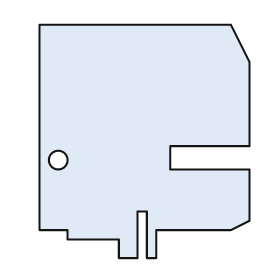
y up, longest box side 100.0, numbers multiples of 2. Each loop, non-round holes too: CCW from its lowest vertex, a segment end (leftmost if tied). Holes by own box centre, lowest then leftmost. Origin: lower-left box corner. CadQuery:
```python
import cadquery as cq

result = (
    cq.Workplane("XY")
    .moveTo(34.0, 0.0)
    .lineTo(42.0, 0.0)
    .lineTo(42.0, 20.0)
    .lineTo(46.0, 20.0)
    .lineTo(46.0, 0.0)
    .lineTo(50.0, 0.0)
    .lineTo(50.0, 12.0)
    .lineTo(82.0, 12.0)
    .lineTo(90.0, 16.0)
    .lineTo(90.0, 38.0)
    .lineTo(56.0, 38.0)
    .lineTo(56.0, 48.0)
    .lineTo(90.0, 48.0)
    .lineTo(90.0, 84.0)
    .lineTo(82.0, 100.0)
    .lineTo(0.0, 100.0)
    .lineTo(0.0, 12.0)
    .lineTo(12.0, 12.0)
    .lineTo(12.0, 8.0)
    .lineTo(34.0, 8.0)
    .close()
    .moveTo(8.0, 42.0)
    .circle(4.0)
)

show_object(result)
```